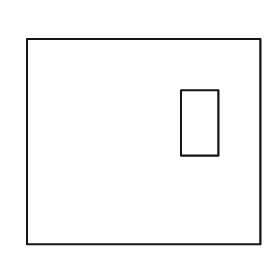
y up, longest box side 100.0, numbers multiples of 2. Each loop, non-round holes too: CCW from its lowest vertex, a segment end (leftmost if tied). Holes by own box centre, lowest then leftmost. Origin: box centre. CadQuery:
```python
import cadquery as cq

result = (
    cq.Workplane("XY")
    .moveTo(-50.0, -44.0)
    .lineTo(50.0, -44.0)
    .lineTo(50.0, 44.0)
    .lineTo(-50.0, 44.0)
    .close()
    .moveTo(16.0, -6.0)
    .lineTo(32.0, -6.0)
    .lineTo(32.0, 22.0)
    .lineTo(16.0, 22.0)
    .close()
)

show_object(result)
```